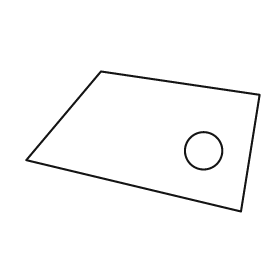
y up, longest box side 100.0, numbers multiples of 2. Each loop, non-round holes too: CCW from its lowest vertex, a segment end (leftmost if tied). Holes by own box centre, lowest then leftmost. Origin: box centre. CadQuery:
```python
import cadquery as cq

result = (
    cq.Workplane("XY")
    .moveTo(42.0, -30.0)
    .lineTo(50.0, 20.0)
    .lineTo(-18.0, 30.0)
    .lineTo(-50.0, -8.0)
    .close()
    .moveTo(26.0, -4.0)
    .circle(8.0)
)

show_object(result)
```